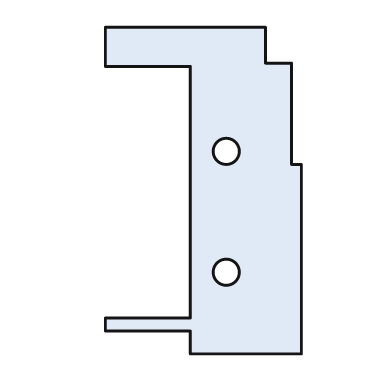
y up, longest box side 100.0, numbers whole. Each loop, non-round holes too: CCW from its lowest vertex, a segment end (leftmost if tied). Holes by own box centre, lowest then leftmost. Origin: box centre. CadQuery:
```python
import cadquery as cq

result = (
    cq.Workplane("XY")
    .moveTo(-4.0, -50.0)
    .lineTo(30.0, -50.0)
    .lineTo(30.0, 8.0)
    .lineTo(27.0, 8.0)
    .lineTo(27.0, 39.0)
    .lineTo(19.0, 39.0)
    .lineTo(19.0, 50.0)
    .lineTo(-30.0, 50.0)
    .lineTo(-30.0, 38.0)
    .lineTo(-4.0, 38.0)
    .lineTo(-4.0, -39.0)
    .lineTo(-30.0, -39.0)
    .lineTo(-30.0, -43.0)
    .lineTo(-4.0, -43.0)
    .close()
    .moveTo(7.0, -25.0)
    .circle(4.0)
    .moveTo(7.0, 12.0)
    .circle(4.0)
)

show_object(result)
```